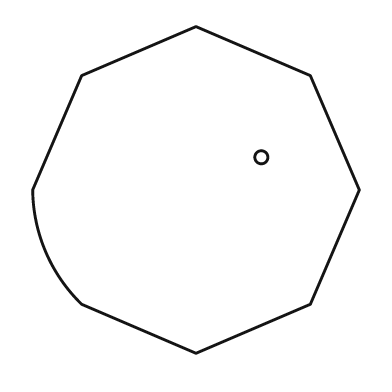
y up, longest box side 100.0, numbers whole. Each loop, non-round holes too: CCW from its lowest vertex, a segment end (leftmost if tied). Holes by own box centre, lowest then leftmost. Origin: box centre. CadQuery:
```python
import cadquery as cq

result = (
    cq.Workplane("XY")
    .moveTo(0.0, -50.0)
    .lineTo(35.0, -35.0)
    .lineTo(50.0, 0.0)
    .lineTo(35.0, 35.0)
    .lineTo(0.0, 50.0)
    .lineTo(-35.0, 35.0)
    .lineTo(-50.0, 0.0)
    .threePointArc((-46.0, -19.0), (-35.0, -35.0))
    .close()
    .moveTo(20.0, 10.0)
    .circle(2.0)
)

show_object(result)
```